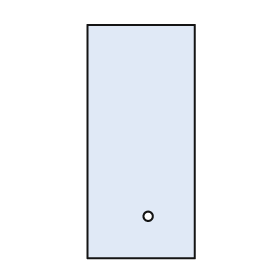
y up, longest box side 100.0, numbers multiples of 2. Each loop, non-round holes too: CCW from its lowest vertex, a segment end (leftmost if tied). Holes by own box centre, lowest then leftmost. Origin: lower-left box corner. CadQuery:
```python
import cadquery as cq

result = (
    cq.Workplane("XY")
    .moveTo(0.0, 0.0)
    .lineTo(46.0, 0.0)
    .lineTo(46.0, 100.0)
    .lineTo(0.0, 100.0)
    .close()
    .moveTo(26.0, 18.0)
    .circle(2.0)
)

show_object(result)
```